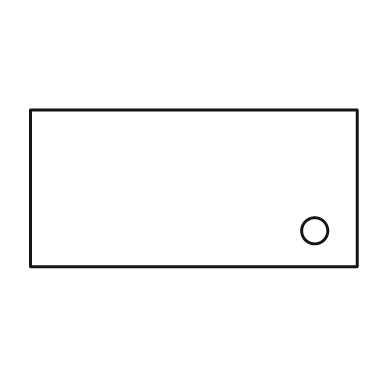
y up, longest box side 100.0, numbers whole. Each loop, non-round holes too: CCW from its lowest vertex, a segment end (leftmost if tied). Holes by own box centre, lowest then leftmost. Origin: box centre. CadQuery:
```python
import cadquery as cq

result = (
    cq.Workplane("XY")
    .moveTo(-50.0, -24.0)
    .lineTo(50.0, -24.0)
    .lineTo(50.0, 24.0)
    .lineTo(-50.0, 24.0)
    .close()
    .moveTo(37.0, -13.0)
    .circle(4.0)
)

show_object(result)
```